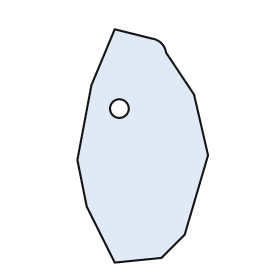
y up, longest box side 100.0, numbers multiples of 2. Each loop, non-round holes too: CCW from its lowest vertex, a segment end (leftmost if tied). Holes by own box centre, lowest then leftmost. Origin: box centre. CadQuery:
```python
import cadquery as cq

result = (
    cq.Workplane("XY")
    .moveTo(-12.0, -50.0)
    .lineTo(8.0, -48.0)
    .lineTo(18.0, -38.0)
    .lineTo(28.0, -4.0)
    .lineTo(22.0, 22.0)
    .lineTo(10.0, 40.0)
    .threePointArc((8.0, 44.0), (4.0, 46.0))
    .lineTo(-12.0, 50.0)
    .lineTo(-22.0, 26.0)
    .lineTo(-28.0, -6.0)
    .lineTo(-24.0, -26.0)
    .close()
    .moveTo(-10.0, 16.0)
    .circle(4.0)
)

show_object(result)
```